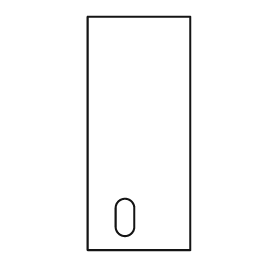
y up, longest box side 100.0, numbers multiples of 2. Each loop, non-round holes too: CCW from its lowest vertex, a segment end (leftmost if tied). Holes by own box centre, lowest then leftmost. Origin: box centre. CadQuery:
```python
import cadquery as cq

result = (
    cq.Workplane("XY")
    .moveTo(-22.0, -50.0)
    .lineTo(22.0, -50.0)
    .lineTo(22.0, 50.0)
    .lineTo(-22.0, 50.0)
    .close()
    .moveTo(-10.0, -40.0)
    .threePointArc((-6.0, -44.0), (-2.0, -40.0))
    .lineTo(-2.0, -32.0)
    .threePointArc((-6.0, -28.0), (-10.0, -32.0))
    .close()
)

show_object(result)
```